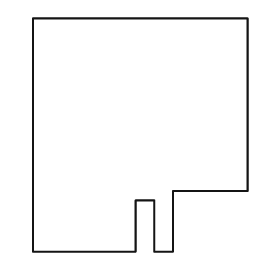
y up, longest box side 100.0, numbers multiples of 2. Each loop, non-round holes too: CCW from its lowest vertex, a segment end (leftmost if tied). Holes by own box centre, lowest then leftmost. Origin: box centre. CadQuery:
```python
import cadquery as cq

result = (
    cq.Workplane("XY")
    .moveTo(-46.0, -50.0)
    .lineTo(-2.0, -50.0)
    .lineTo(-2.0, -28.0)
    .lineTo(6.0, -28.0)
    .lineTo(6.0, -50.0)
    .lineTo(14.0, -50.0)
    .lineTo(14.0, -24.0)
    .lineTo(46.0, -24.0)
    .lineTo(46.0, 50.0)
    .lineTo(-46.0, 50.0)
    .close()
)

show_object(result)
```